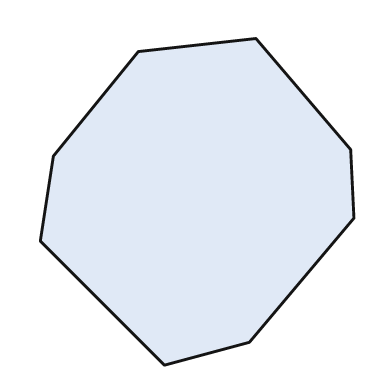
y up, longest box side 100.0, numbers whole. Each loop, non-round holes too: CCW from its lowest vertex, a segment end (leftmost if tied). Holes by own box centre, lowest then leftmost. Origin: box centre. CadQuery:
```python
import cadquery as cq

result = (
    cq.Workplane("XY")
    .moveTo(-10.0, -50.0)
    .lineTo(16.0, -43.0)
    .lineTo(48.0, -5.0)
    .lineTo(47.0, 16.0)
    .lineTo(18.0, 50.0)
    .lineTo(-18.0, 46.0)
    .lineTo(-44.0, 14.0)
    .lineTo(-48.0, -12.0)
    .close()
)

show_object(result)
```